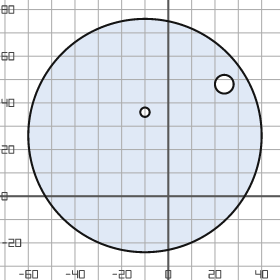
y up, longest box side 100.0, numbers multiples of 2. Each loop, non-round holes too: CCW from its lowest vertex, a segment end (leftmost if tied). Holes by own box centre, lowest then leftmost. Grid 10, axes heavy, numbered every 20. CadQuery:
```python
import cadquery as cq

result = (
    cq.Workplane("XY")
    .moveTo(-10.0, 26.0)
    .circle(50.0)
    .moveTo(-10.0, 36.0)
    .circle(2.0)
    .moveTo(24.0, 48.0)
    .circle(4.0)
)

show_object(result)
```